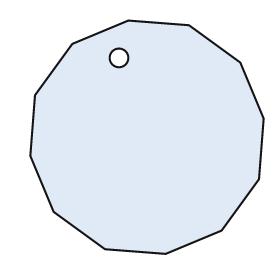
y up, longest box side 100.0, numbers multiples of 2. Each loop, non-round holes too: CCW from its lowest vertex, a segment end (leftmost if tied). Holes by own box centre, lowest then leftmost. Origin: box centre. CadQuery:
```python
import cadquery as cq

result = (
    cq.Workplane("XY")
    .moveTo(8.0, -50.0)
    .lineTo(32.0, -40.0)
    .lineTo(48.0, -18.0)
    .lineTo(50.0, 8.0)
    .lineTo(40.0, 32.0)
    .lineTo(18.0, 48.0)
    .lineTo(-8.0, 50.0)
    .lineTo(-32.0, 40.0)
    .lineTo(-48.0, 18.0)
    .lineTo(-50.0, -8.0)
    .lineTo(-40.0, -32.0)
    .lineTo(-18.0, -48.0)
    .close()
    .moveTo(-12.0, 34.0)
    .circle(4.0)
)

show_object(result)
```